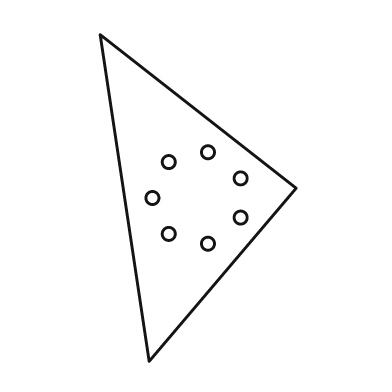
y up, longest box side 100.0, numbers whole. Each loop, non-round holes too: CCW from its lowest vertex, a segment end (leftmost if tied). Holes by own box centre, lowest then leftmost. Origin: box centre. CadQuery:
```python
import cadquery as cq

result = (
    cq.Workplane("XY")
    .moveTo(-15.0, -50.0)
    .lineTo(30.0, 3.0)
    .lineTo(-30.0, 50.0)
    .close()
    .moveTo(3.0, -14.0)
    .circle(2.0)
    .moveTo(-9.0, -11.0)
    .circle(2.0)
    .moveTo(13.0, -6.0)
    .circle(2.0)
    .moveTo(-14.0, 0.0)
    .circle(2.0)
    .moveTo(13.0, 6.0)
    .circle(2.0)
    .moveTo(-9.0, 11.0)
    .circle(2.0)
    .moveTo(3.0, 14.0)
    .circle(2.0)
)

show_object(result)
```